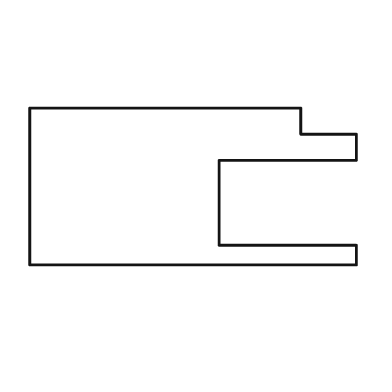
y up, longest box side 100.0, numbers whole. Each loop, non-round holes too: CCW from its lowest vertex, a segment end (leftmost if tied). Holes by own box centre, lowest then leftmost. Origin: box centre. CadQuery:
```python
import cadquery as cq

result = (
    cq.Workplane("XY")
    .moveTo(-50.0, -24.0)
    .lineTo(50.0, -24.0)
    .lineTo(50.0, -18.0)
    .lineTo(8.0, -18.0)
    .lineTo(8.0, 8.0)
    .lineTo(50.0, 8.0)
    .lineTo(50.0, 16.0)
    .lineTo(33.0, 16.0)
    .lineTo(33.0, 24.0)
    .lineTo(-50.0, 24.0)
    .close()
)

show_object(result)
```